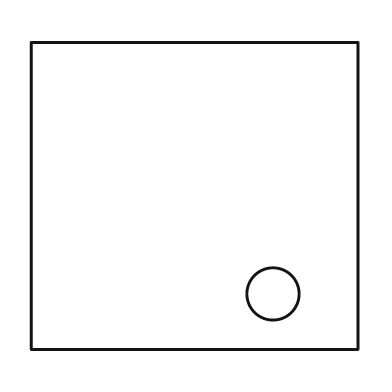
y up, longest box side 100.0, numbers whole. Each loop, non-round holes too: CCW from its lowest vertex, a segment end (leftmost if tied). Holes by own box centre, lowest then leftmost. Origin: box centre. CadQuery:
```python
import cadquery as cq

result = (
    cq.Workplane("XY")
    .moveTo(-50.0, -47.0)
    .lineTo(50.0, -47.0)
    .lineTo(50.0, 47.0)
    .lineTo(-50.0, 47.0)
    .close()
    .moveTo(24.0, -30.0)
    .circle(8.0)
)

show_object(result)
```